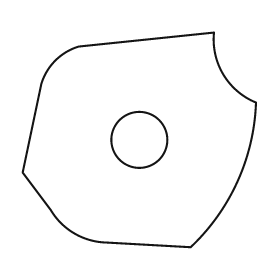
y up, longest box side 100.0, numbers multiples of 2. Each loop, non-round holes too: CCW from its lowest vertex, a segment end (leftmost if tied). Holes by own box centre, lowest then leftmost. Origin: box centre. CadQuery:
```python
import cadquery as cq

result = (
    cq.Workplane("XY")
    .moveTo(22.0, -46.0)
    .threePointArc((42.0, -18.0), (50.0, 16.0))
    .threePointArc((36.0, 28.0), (32.0, 46.0))
    .lineTo(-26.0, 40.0)
    .threePointArc((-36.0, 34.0), (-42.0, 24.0))
    .lineTo(-50.0, -14.0)
    .lineTo(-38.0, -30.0)
    .threePointArc((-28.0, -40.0), (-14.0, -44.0))
    .close()
    .moveTo(0.0, 0.0)
    .circle(12.0)
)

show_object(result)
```